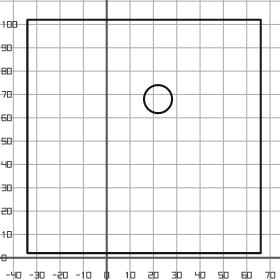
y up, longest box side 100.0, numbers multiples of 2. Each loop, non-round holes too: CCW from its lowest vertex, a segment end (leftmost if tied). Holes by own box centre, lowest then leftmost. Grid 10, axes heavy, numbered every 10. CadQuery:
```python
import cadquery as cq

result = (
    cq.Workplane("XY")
    .moveTo(-34.0, 2.0)
    .lineTo(66.0, 2.0)
    .lineTo(66.0, 102.0)
    .lineTo(-34.0, 102.0)
    .close()
    .moveTo(22.0, 68.0)
    .circle(6.0)
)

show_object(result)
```